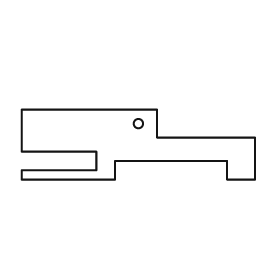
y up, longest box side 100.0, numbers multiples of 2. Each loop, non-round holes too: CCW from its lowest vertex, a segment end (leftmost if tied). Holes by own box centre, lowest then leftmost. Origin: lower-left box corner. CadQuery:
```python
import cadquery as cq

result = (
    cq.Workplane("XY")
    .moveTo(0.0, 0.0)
    .lineTo(40.0, 0.0)
    .lineTo(40.0, 8.0)
    .lineTo(88.0, 8.0)
    .lineTo(88.0, 0.0)
    .lineTo(100.0, 0.0)
    .lineTo(100.0, 18.0)
    .lineTo(58.0, 18.0)
    .lineTo(58.0, 30.0)
    .lineTo(0.0, 30.0)
    .lineTo(0.0, 12.0)
    .lineTo(32.0, 12.0)
    .lineTo(32.0, 4.0)
    .lineTo(0.0, 4.0)
    .close()
    .moveTo(50.0, 24.0)
    .circle(2.0)
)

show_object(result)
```